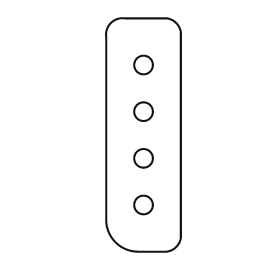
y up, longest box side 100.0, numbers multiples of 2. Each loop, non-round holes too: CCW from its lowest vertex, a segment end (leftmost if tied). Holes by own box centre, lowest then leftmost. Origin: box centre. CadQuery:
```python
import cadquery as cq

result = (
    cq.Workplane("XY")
    .moveTo(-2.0, -50.0)
    .lineTo(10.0, -50.0)
    .threePointArc((14.0, -48.0), (16.0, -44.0))
    .lineTo(16.0, 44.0)
    .threePointArc((14.0, 48.0), (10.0, 50.0))
    .lineTo(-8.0, 50.0)
    .threePointArc((-14.0, 48.0), (-16.0, 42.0))
    .lineTo(-16.0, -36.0)
    .threePointArc((-12.0, -46.0), (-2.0, -50.0))
    .close()
    .moveTo(0.0, -30.0)
    .circle(4.0)
    .moveTo(0.0, -10.0)
    .circle(4.0)
    .moveTo(0.0, 10.0)
    .circle(4.0)
    .moveTo(0.0, 30.0)
    .circle(4.0)
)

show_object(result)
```